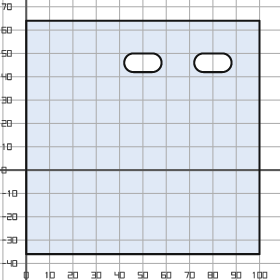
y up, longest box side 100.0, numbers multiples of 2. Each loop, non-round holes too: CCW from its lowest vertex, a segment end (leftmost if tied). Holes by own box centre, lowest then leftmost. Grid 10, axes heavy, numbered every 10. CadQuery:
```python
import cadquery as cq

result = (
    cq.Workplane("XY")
    .moveTo(0.0, -36.0)
    .lineTo(100.0, -36.0)
    .lineTo(100.0, 64.0)
    .lineTo(0.0, 64.0)
    .close()
    .moveTo(46.0, 42.0)
    .lineTo(54.0, 42.0)
    .threePointArc((58.0, 46.0), (54.0, 50.0))
    .lineTo(46.0, 50.0)
    .threePointArc((42.0, 46.0), (46.0, 42.0))
    .close()
    .moveTo(76.0, 42.0)
    .lineTo(84.0, 42.0)
    .threePointArc((88.0, 46.0), (84.0, 50.0))
    .lineTo(76.0, 50.0)
    .threePointArc((72.0, 46.0), (76.0, 42.0))
    .close()
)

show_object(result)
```